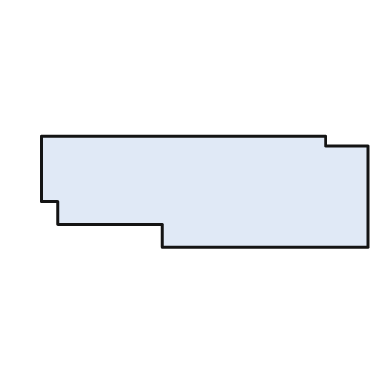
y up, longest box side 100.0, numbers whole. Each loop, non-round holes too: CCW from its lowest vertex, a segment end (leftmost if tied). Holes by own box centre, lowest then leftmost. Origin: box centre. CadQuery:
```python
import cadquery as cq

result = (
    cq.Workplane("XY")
    .moveTo(-13.0, -17.0)
    .lineTo(50.0, -17.0)
    .lineTo(50.0, 14.0)
    .lineTo(37.0, 14.0)
    .lineTo(37.0, 17.0)
    .lineTo(-50.0, 17.0)
    .lineTo(-50.0, -3.0)
    .lineTo(-45.0, -3.0)
    .lineTo(-45.0, -10.0)
    .lineTo(-13.0, -10.0)
    .close()
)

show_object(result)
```